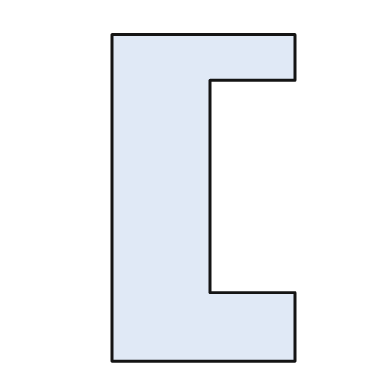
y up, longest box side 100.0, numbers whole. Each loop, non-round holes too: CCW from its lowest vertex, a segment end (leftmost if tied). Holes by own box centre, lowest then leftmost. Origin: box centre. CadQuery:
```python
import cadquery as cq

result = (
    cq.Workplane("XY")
    .moveTo(-28.0, -50.0)
    .lineTo(28.0, -50.0)
    .lineTo(28.0, -29.0)
    .lineTo(2.0, -29.0)
    .lineTo(2.0, 36.0)
    .lineTo(28.0, 36.0)
    .lineTo(28.0, 50.0)
    .lineTo(-28.0, 50.0)
    .close()
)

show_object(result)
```